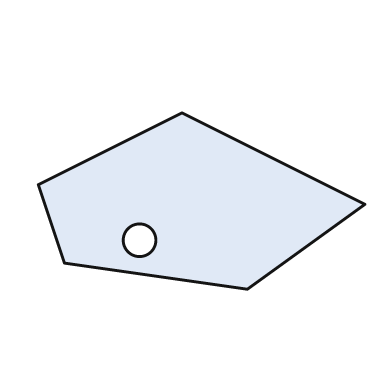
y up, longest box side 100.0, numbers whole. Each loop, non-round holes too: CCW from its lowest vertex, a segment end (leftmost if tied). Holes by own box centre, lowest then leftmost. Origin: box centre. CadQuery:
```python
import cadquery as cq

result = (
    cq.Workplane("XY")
    .moveTo(14.0, -27.0)
    .lineTo(50.0, -1.0)
    .lineTo(-6.0, 27.0)
    .lineTo(-50.0, 5.0)
    .lineTo(-42.0, -19.0)
    .close()
    .moveTo(-19.0, -12.0)
    .circle(5.0)
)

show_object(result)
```